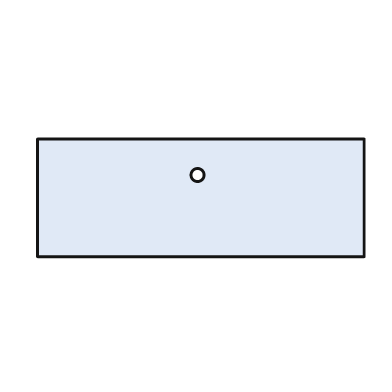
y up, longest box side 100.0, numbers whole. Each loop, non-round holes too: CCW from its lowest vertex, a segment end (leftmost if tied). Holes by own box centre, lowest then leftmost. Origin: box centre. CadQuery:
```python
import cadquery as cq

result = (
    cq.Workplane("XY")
    .moveTo(-50.0, -18.0)
    .lineTo(50.0, -18.0)
    .lineTo(50.0, 18.0)
    .lineTo(-50.0, 18.0)
    .close()
    .moveTo(-1.0, 7.0)
    .circle(2.0)
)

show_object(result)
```